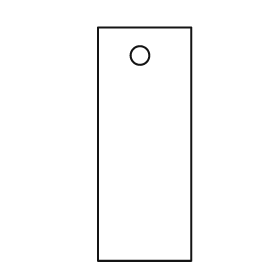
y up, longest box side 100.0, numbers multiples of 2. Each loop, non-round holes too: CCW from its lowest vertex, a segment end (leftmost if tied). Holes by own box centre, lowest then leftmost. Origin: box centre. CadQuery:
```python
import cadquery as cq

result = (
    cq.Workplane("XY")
    .moveTo(-20.0, -50.0)
    .lineTo(20.0, -50.0)
    .lineTo(20.0, 50.0)
    .lineTo(-20.0, 50.0)
    .close()
    .moveTo(-2.0, 38.0)
    .circle(4.0)
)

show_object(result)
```